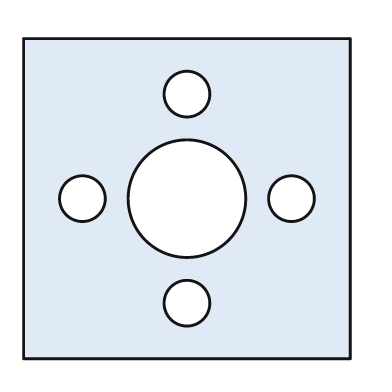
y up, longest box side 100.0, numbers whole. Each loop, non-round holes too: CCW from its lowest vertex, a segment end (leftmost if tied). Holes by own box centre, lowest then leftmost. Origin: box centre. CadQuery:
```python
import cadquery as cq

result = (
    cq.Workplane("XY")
    .moveTo(-50.0, -49.0)
    .lineTo(50.0, -49.0)
    .lineTo(50.0, 49.0)
    .lineTo(-50.0, 49.0)
    .close()
    .moveTo(0.0, -32.0)
    .circle(7.0)
    .moveTo(-32.0, 0.0)
    .circle(7.0)
    .moveTo(0.0, 0.0)
    .circle(18.0)
    .moveTo(32.0, 0.0)
    .circle(7.0)
    .moveTo(0.0, 32.0)
    .circle(7.0)
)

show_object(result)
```